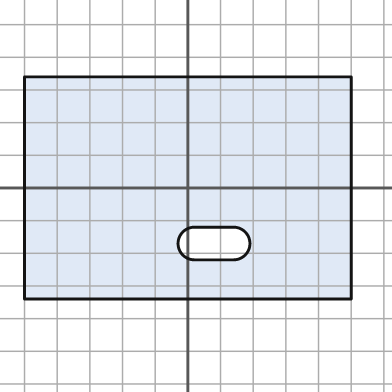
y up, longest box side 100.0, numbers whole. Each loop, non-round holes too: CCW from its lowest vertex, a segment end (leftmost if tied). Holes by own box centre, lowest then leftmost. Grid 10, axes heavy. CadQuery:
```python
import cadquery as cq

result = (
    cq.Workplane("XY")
    .moveTo(-50.0, -34.0)
    .lineTo(50.0, -34.0)
    .lineTo(50.0, 34.0)
    .lineTo(-50.0, 34.0)
    .close()
    .moveTo(2.0, -22.0)
    .lineTo(14.0, -22.0)
    .threePointArc((19.0, -17.0), (14.0, -12.0))
    .lineTo(2.0, -12.0)
    .threePointArc((-3.0, -17.0), (2.0, -22.0))
    .close()
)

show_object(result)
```